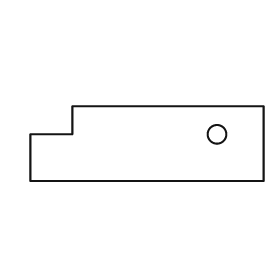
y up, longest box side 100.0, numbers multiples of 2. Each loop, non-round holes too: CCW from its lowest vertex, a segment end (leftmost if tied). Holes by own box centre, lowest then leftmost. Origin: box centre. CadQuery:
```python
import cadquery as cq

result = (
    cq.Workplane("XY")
    .moveTo(-50.0, -16.0)
    .lineTo(50.0, -16.0)
    .lineTo(50.0, 16.0)
    .lineTo(-32.0, 16.0)
    .lineTo(-32.0, 4.0)
    .lineTo(-50.0, 4.0)
    .close()
    .moveTo(30.0, 4.0)
    .circle(4.0)
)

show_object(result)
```